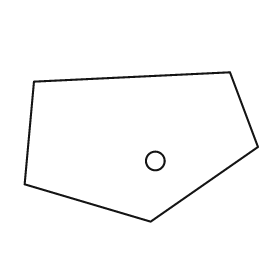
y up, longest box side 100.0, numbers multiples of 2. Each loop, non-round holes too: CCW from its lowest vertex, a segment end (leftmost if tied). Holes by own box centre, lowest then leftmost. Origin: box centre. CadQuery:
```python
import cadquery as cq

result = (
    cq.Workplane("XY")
    .moveTo(4.0, -32.0)
    .lineTo(50.0, 0.0)
    .lineTo(38.0, 32.0)
    .lineTo(-46.0, 28.0)
    .lineTo(-50.0, -16.0)
    .close()
    .moveTo(6.0, -6.0)
    .circle(4.0)
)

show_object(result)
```